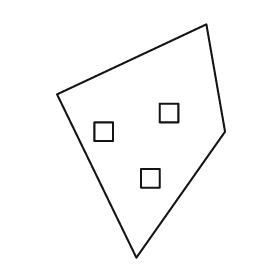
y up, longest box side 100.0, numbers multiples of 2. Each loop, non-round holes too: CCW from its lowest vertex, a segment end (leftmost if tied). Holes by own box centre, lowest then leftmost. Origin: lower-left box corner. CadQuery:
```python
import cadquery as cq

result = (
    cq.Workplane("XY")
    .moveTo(34.0, 0.0)
    .lineTo(72.0, 54.0)
    .lineTo(64.0, 100.0)
    .lineTo(0.0, 70.0)
    .close()
    .moveTo(36.0, 30.0)
    .lineTo(44.0, 30.0)
    .lineTo(44.0, 38.0)
    .lineTo(36.0, 38.0)
    .close()
    .moveTo(16.0, 50.0)
    .lineTo(24.0, 50.0)
    .lineTo(24.0, 58.0)
    .lineTo(16.0, 58.0)
    .close()
    .moveTo(44.0, 58.0)
    .lineTo(52.0, 58.0)
    .lineTo(52.0, 66.0)
    .lineTo(44.0, 66.0)
    .close()
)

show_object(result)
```